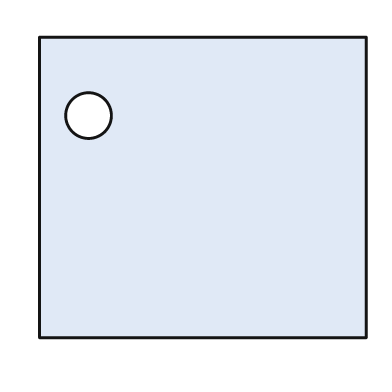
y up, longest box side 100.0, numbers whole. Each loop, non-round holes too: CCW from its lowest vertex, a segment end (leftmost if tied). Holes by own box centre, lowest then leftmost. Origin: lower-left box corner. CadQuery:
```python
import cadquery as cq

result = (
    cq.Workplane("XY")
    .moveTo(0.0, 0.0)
    .lineTo(100.0, 0.0)
    .lineTo(100.0, 92.0)
    .lineTo(0.0, 92.0)
    .close()
    .moveTo(15.0, 68.0)
    .circle(7.0)
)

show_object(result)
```